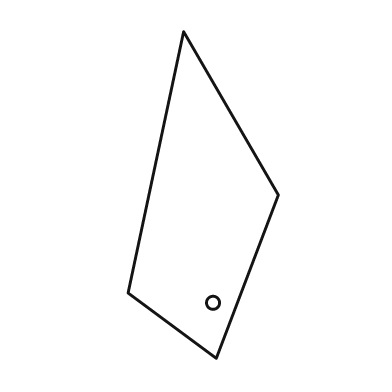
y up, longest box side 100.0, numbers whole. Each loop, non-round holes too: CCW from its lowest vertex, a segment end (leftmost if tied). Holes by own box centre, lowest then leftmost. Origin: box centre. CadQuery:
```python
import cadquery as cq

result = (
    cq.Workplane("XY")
    .moveTo(4.0, -50.0)
    .lineTo(23.0, 0.0)
    .lineTo(-6.0, 50.0)
    .lineTo(-23.0, -30.0)
    .close()
    .moveTo(3.0, -33.0)
    .circle(2.0)
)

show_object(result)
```